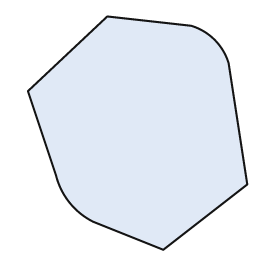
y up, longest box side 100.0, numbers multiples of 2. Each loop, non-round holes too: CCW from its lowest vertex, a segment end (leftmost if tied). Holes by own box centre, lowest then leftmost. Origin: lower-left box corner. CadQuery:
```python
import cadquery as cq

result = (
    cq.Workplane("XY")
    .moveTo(58.0, 0.0)
    .lineTo(94.0, 28.0)
    .lineTo(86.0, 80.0)
    .threePointArc((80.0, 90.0), (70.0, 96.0))
    .lineTo(34.0, 100.0)
    .lineTo(0.0, 68.0)
    .lineTo(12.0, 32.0)
    .threePointArc((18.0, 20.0), (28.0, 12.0))
    .close()
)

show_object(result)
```